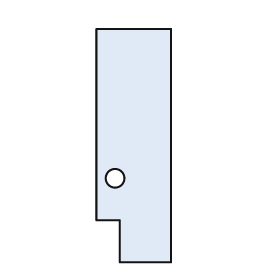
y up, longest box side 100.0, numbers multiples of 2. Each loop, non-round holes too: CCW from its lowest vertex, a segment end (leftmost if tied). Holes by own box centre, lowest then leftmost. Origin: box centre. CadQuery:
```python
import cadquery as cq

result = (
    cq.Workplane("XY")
    .moveTo(-6.0, -50.0)
    .lineTo(16.0, -50.0)
    .lineTo(16.0, 50.0)
    .lineTo(-16.0, 50.0)
    .lineTo(-16.0, -32.0)
    .lineTo(-6.0, -32.0)
    .close()
    .moveTo(-8.0, -14.0)
    .circle(4.0)
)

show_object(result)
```